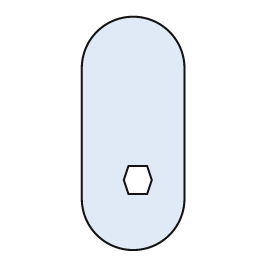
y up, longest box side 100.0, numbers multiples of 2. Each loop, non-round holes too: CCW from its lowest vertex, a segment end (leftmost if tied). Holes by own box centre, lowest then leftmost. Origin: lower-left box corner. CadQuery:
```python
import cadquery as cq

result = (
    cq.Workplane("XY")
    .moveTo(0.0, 22.0)
    .threePointArc((22.0, 0.0), (44.0, 22.0))
    .lineTo(44.0, 78.0)
    .threePointArc((22.0, 100.0), (0.0, 78.0))
    .close()
    .moveTo(20.0, 24.0)
    .lineTo(28.0, 24.0)
    .lineTo(30.0, 30.0)
    .lineTo(28.0, 36.0)
    .lineTo(20.0, 36.0)
    .lineTo(18.0, 30.0)
    .close()
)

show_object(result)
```